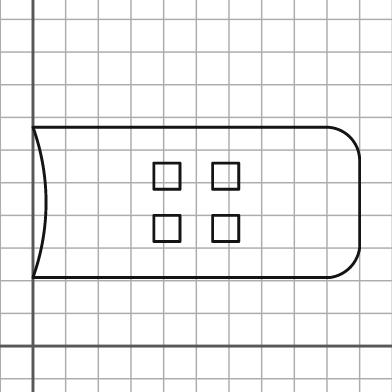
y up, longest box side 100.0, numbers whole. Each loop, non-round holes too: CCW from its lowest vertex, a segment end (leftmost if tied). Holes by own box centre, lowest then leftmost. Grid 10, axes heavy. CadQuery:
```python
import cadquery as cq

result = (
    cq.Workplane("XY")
    .moveTo(0.0, 21.0)
    .lineTo(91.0, 21.0)
    .threePointArc((97.0, 24.0), (100.0, 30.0))
    .lineTo(100.0, 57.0)
    .threePointArc((97.0, 64.0), (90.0, 67.0))
    .lineTo(0.0, 67.0)
    .threePointArc((4.0, 44.0), (0.0, 21.0))
    .close()
    .moveTo(37.0, 32.0)
    .lineTo(45.0, 32.0)
    .lineTo(45.0, 40.0)
    .lineTo(37.0, 40.0)
    .close()
    .moveTo(55.0, 32.0)
    .lineTo(63.0, 32.0)
    .lineTo(63.0, 40.0)
    .lineTo(55.0, 40.0)
    .close()
    .moveTo(37.0, 48.0)
    .lineTo(45.0, 48.0)
    .lineTo(45.0, 56.0)
    .lineTo(37.0, 56.0)
    .close()
    .moveTo(55.0, 48.0)
    .lineTo(63.0, 48.0)
    .lineTo(63.0, 56.0)
    .lineTo(55.0, 56.0)
    .close()
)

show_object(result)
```